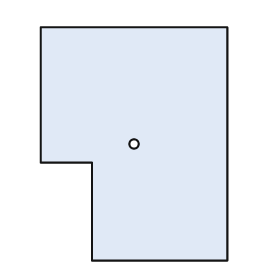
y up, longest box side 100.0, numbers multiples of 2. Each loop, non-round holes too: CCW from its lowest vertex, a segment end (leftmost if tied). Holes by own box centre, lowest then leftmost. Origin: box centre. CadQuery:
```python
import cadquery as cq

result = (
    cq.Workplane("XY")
    .moveTo(-18.0, -50.0)
    .lineTo(40.0, -50.0)
    .lineTo(40.0, 50.0)
    .lineTo(-40.0, 50.0)
    .lineTo(-40.0, -8.0)
    .lineTo(-18.0, -8.0)
    .close()
    .moveTo(0.0, 0.0)
    .circle(2.0)
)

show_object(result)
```